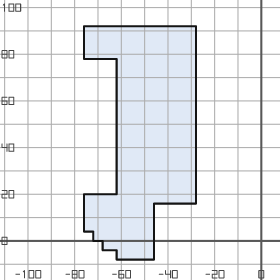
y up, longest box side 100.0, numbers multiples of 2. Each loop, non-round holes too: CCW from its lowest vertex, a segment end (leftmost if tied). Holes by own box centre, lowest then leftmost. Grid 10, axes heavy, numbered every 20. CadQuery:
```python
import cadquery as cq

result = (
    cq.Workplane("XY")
    .moveTo(-62.0, -8.0)
    .lineTo(-46.0, -8.0)
    .lineTo(-46.0, 16.0)
    .lineTo(-28.0, 16.0)
    .lineTo(-28.0, 92.0)
    .lineTo(-76.0, 92.0)
    .lineTo(-76.0, 78.0)
    .lineTo(-62.0, 78.0)
    .lineTo(-62.0, 20.0)
    .lineTo(-76.0, 20.0)
    .lineTo(-76.0, 4.0)
    .lineTo(-72.0, 4.0)
    .lineTo(-72.0, 0.0)
    .lineTo(-68.0, 0.0)
    .lineTo(-68.0, -4.0)
    .lineTo(-62.0, -4.0)
    .close()
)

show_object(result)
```